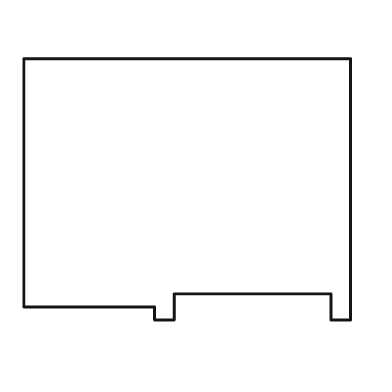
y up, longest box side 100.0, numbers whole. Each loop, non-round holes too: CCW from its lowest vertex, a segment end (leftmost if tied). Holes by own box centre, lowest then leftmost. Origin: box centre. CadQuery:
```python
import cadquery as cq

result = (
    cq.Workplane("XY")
    .moveTo(-10.0, -40.0)
    .lineTo(-4.0, -40.0)
    .lineTo(-4.0, -32.0)
    .lineTo(44.0, -32.0)
    .lineTo(44.0, -40.0)
    .lineTo(50.0, -40.0)
    .lineTo(50.0, 40.0)
    .lineTo(-50.0, 40.0)
    .lineTo(-50.0, -36.0)
    .lineTo(-10.0, -36.0)
    .close()
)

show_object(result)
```